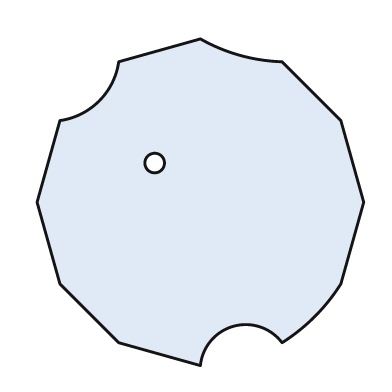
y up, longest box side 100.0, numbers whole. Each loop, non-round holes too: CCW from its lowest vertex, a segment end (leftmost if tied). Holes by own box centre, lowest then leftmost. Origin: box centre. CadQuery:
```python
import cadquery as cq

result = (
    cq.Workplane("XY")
    .moveTo(0.0, -50.0)
    .threePointArc((10.0, -38.0), (25.0, -43.0))
    .threePointArc((35.0, -35.0), (43.0, -25.0))
    .lineTo(50.0, 0.0)
    .lineTo(43.0, 25.0)
    .lineTo(25.0, 43.0)
    .threePointArc((12.0, 45.0), (0.0, 50.0))
    .lineTo(-25.0, 43.0)
    .threePointArc((-31.0, 31.0), (-43.0, 25.0))
    .lineTo(-50.0, 0.0)
    .lineTo(-43.0, -25.0)
    .lineTo(-25.0, -43.0)
    .close()
    .moveTo(-14.0, 12.0)
    .circle(3.0)
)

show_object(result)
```